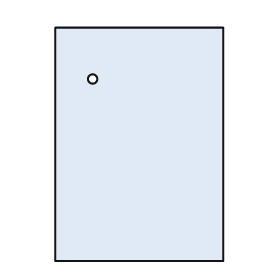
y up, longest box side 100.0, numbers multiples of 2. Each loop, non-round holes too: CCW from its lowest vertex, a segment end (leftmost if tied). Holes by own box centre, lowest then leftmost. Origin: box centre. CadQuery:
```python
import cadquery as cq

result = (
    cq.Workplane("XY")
    .moveTo(-36.0, -50.0)
    .lineTo(36.0, -50.0)
    .lineTo(36.0, 50.0)
    .lineTo(-36.0, 50.0)
    .close()
    .moveTo(-20.0, 28.0)
    .circle(2.0)
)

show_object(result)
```